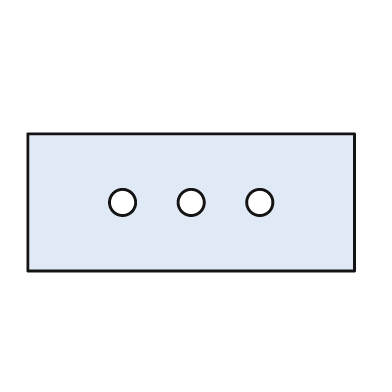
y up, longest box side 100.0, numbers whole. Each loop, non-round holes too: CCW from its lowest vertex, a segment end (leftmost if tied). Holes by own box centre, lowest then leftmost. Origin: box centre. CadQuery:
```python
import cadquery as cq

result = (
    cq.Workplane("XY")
    .moveTo(-50.0, -21.0)
    .lineTo(50.0, -21.0)
    .lineTo(50.0, 21.0)
    .lineTo(-50.0, 21.0)
    .close()
    .moveTo(-21.0, 0.0)
    .circle(4.0)
    .moveTo(0.0, 0.0)
    .circle(4.0)
    .moveTo(21.0, 0.0)
    .circle(4.0)
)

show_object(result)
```